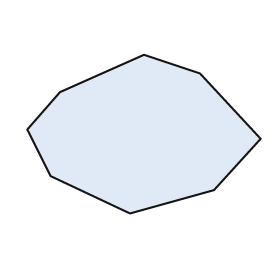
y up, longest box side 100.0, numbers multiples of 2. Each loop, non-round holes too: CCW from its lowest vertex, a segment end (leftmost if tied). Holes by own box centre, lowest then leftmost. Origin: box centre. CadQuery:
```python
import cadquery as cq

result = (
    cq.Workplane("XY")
    .moveTo(-6.0, -34.0)
    .lineTo(30.0, -24.0)
    .lineTo(50.0, -2.0)
    .lineTo(24.0, 26.0)
    .lineTo(0.0, 34.0)
    .lineTo(-36.0, 18.0)
    .lineTo(-50.0, 2.0)
    .lineTo(-40.0, -18.0)
    .close()
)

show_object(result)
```